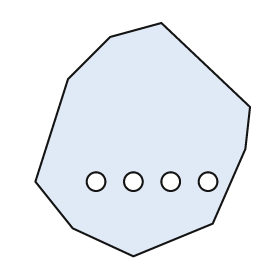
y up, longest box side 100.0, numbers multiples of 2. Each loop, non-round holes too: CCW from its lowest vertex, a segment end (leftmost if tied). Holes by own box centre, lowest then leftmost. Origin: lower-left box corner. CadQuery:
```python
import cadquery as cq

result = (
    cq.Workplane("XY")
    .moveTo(42.0, 0.0)
    .lineTo(76.0, 14.0)
    .lineTo(90.0, 46.0)
    .lineTo(92.0, 64.0)
    .lineTo(54.0, 100.0)
    .lineTo(32.0, 94.0)
    .lineTo(14.0, 76.0)
    .lineTo(0.0, 32.0)
    .lineTo(16.0, 12.0)
    .close()
    .moveTo(26.0, 32.0)
    .circle(4.0)
    .moveTo(42.0, 32.0)
    .circle(4.0)
    .moveTo(58.0, 32.0)
    .circle(4.0)
    .moveTo(74.0, 32.0)
    .circle(4.0)
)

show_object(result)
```